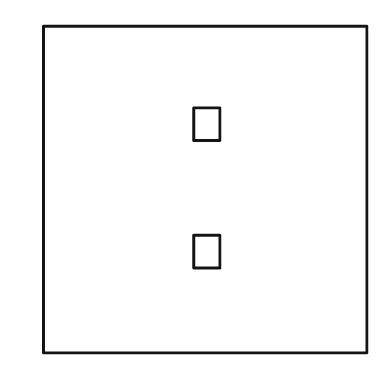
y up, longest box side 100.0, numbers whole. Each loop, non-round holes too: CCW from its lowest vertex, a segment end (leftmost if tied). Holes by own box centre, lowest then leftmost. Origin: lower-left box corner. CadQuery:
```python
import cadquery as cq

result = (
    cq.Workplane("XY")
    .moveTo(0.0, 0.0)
    .lineTo(99.0, 0.0)
    .lineTo(99.0, 100.0)
    .lineTo(0.0, 100.0)
    .close()
    .moveTo(46.0, 26.0)
    .lineTo(54.0, 26.0)
    .lineTo(54.0, 36.0)
    .lineTo(46.0, 36.0)
    .close()
    .moveTo(46.0, 65.0)
    .lineTo(54.0, 65.0)
    .lineTo(54.0, 75.0)
    .lineTo(46.0, 75.0)
    .close()
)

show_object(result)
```